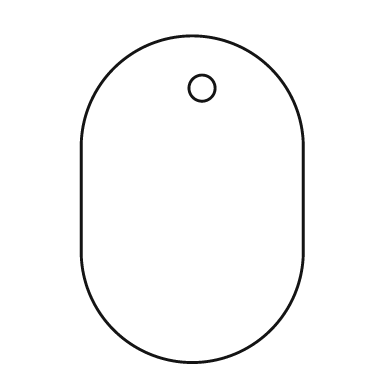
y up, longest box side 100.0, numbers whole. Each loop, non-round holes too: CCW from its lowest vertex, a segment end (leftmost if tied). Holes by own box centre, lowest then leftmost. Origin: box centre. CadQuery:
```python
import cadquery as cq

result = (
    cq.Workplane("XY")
    .moveTo(-34.0, -16.0)
    .threePointArc((0.0, -50.0), (34.0, -16.0))
    .lineTo(34.0, 16.0)
    .threePointArc((0.0, 50.0), (-34.0, 16.0))
    .close()
    .moveTo(3.0, 34.0)
    .circle(4.0)
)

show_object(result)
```